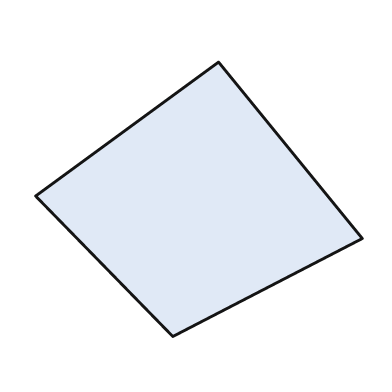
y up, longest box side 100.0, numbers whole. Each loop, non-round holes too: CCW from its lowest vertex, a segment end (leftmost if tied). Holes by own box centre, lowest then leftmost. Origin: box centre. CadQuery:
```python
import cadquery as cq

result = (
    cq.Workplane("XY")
    .moveTo(-8.0, -42.0)
    .lineTo(50.0, -12.0)
    .lineTo(6.0, 42.0)
    .lineTo(-50.0, 1.0)
    .close()
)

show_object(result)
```